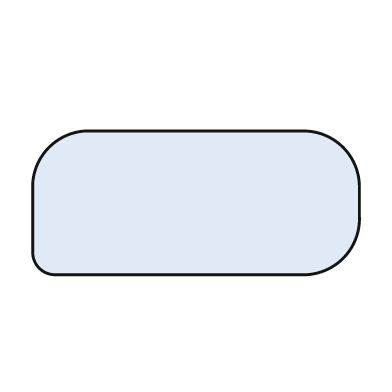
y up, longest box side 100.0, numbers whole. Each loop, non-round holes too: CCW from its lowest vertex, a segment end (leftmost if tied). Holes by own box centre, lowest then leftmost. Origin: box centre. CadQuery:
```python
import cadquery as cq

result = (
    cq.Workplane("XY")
    .moveTo(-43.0, -22.0)
    .lineTo(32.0, -22.0)
    .threePointArc((45.0, -17.0), (50.0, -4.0))
    .lineTo(50.0, 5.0)
    .threePointArc((45.0, 17.0), (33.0, 22.0))
    .lineTo(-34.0, 22.0)
    .threePointArc((-45.0, 17.0), (-50.0, 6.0))
    .lineTo(-50.0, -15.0)
    .threePointArc((-48.0, -20.0), (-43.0, -22.0))
    .close()
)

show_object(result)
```